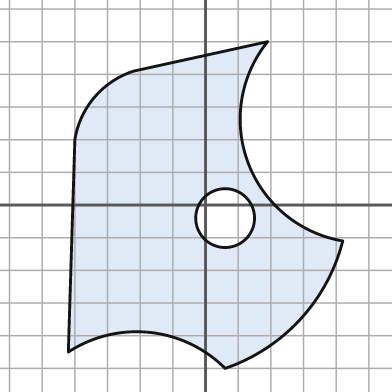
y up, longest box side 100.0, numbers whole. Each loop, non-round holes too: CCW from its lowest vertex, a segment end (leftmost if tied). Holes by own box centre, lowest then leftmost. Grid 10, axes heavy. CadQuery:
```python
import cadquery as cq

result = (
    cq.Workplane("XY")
    .moveTo(6.0, -50.0)
    .threePointArc((29.0, -35.0), (42.0, -11.0))
    .threePointArc((13.0, 13.0), (19.0, 50.0))
    .lineTo(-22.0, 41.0)
    .threePointArc((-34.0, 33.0), (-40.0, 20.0))
    .lineTo(-42.0, -45.0)
    .threePointArc((-17.0, -39.0), (6.0, -50.0))
    .close()
    .moveTo(6.0, -4.0)
    .circle(9.0)
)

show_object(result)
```